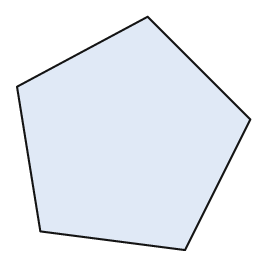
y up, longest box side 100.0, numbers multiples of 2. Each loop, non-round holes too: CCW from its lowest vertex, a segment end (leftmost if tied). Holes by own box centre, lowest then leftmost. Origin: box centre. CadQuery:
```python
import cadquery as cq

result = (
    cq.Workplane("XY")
    .moveTo(22.0, -50.0)
    .lineTo(50.0, 6.0)
    .lineTo(6.0, 50.0)
    .lineTo(-50.0, 20.0)
    .lineTo(-40.0, -42.0)
    .close()
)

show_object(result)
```